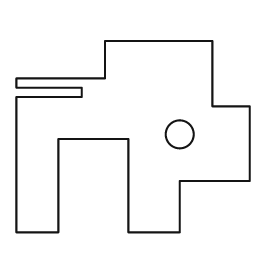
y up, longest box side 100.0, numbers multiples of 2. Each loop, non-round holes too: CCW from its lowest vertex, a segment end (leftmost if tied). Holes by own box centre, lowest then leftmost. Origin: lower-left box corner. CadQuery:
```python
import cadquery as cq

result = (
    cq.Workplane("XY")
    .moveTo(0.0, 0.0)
    .lineTo(18.0, 0.0)
    .lineTo(18.0, 40.0)
    .lineTo(48.0, 40.0)
    .lineTo(48.0, 0.0)
    .lineTo(70.0, 0.0)
    .lineTo(70.0, 22.0)
    .lineTo(100.0, 22.0)
    .lineTo(100.0, 54.0)
    .lineTo(84.0, 54.0)
    .lineTo(84.0, 82.0)
    .lineTo(38.0, 82.0)
    .lineTo(38.0, 66.0)
    .lineTo(0.0, 66.0)
    .lineTo(0.0, 62.0)
    .lineTo(28.0, 62.0)
    .lineTo(28.0, 58.0)
    .lineTo(0.0, 58.0)
    .close()
    .moveTo(70.0, 42.0)
    .circle(6.0)
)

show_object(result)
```